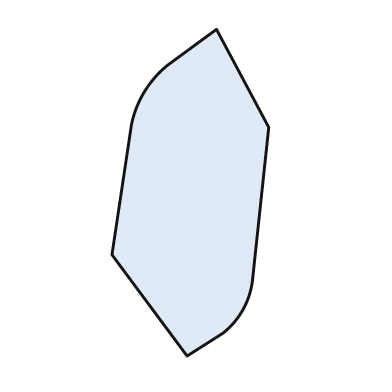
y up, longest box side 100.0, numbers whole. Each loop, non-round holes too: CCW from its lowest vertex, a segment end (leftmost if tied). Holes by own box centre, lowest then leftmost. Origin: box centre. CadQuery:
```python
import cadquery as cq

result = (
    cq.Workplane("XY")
    .moveTo(-1.0, -50.0)
    .lineTo(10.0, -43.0)
    .threePointArc((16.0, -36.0), (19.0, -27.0))
    .lineTo(24.0, 20.0)
    .lineTo(8.0, 50.0)
    .lineTo(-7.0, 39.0)
    .threePointArc((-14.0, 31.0), (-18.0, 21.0))
    .lineTo(-24.0, -19.0)
    .close()
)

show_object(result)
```